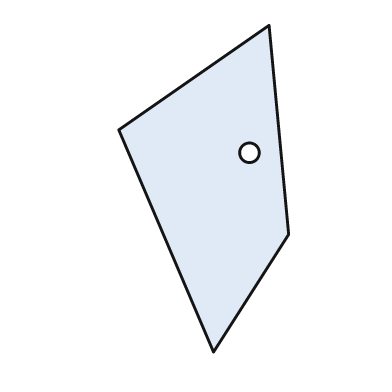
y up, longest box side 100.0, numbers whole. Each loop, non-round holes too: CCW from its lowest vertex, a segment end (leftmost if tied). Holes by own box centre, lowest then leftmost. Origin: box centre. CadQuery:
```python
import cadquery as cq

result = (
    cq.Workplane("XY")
    .moveTo(3.0, -50.0)
    .lineTo(26.0, -14.0)
    .lineTo(20.0, 50.0)
    .lineTo(-26.0, 18.0)
    .close()
    .moveTo(14.0, 11.0)
    .circle(3.0)
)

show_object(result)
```